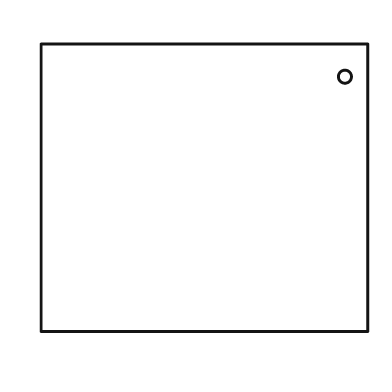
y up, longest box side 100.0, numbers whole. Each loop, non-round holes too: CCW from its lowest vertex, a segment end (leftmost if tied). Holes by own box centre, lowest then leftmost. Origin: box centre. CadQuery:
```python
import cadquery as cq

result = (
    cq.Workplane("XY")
    .moveTo(-50.0, -44.0)
    .lineTo(50.0, -44.0)
    .lineTo(50.0, 44.0)
    .lineTo(-50.0, 44.0)
    .close()
    .moveTo(43.0, 34.0)
    .circle(2.0)
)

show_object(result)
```